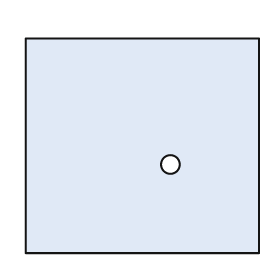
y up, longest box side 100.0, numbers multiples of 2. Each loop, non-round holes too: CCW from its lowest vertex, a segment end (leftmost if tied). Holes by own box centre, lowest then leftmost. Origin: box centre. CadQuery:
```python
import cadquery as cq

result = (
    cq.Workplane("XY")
    .moveTo(-50.0, -46.0)
    .lineTo(50.0, -46.0)
    .lineTo(50.0, 46.0)
    .lineTo(-50.0, 46.0)
    .close()
    .moveTo(12.0, -8.0)
    .circle(4.0)
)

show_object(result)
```